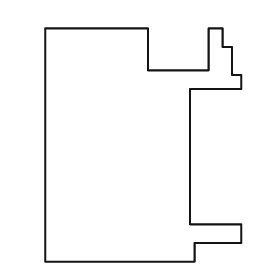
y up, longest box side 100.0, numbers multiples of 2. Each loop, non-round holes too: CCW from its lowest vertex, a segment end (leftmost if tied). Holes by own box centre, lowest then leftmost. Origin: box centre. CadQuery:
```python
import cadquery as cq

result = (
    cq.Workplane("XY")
    .moveTo(-42.0, -50.0)
    .lineTo(22.0, -50.0)
    .lineTo(22.0, -42.0)
    .lineTo(42.0, -42.0)
    .lineTo(42.0, -34.0)
    .lineTo(20.0, -34.0)
    .lineTo(20.0, 24.0)
    .lineTo(42.0, 24.0)
    .lineTo(42.0, 30.0)
    .lineTo(38.0, 30.0)
    .lineTo(38.0, 42.0)
    .lineTo(34.0, 42.0)
    .lineTo(34.0, 50.0)
    .lineTo(28.0, 50.0)
    .lineTo(28.0, 32.0)
    .lineTo(2.0, 32.0)
    .lineTo(2.0, 50.0)
    .lineTo(-42.0, 50.0)
    .close()
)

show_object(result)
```